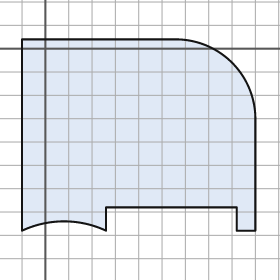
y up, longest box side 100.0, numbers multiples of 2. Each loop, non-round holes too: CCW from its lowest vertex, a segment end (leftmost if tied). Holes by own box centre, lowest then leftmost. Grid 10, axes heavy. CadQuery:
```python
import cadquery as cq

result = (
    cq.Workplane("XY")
    .moveTo(-10.0, -78.0)
    .threePointArc((8.0, -74.0), (26.0, -78.0))
    .lineTo(26.0, -68.0)
    .lineTo(82.0, -68.0)
    .lineTo(82.0, -78.0)
    .lineTo(90.0, -78.0)
    .lineTo(90.0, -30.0)
    .threePointArc((80.0, -6.0), (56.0, 4.0))
    .lineTo(-10.0, 4.0)
    .close()
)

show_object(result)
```